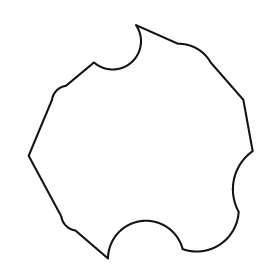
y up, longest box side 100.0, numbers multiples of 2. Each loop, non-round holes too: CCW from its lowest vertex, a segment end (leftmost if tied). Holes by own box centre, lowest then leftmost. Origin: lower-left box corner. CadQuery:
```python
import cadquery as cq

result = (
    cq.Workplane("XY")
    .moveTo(34.0, 0.0)
    .threePointArc((48.0, 16.0), (66.0, 4.0))
    .threePointArc((82.0, 6.0), (90.0, 20.0))
    .threePointArc((88.0, 34.0), (96.0, 46.0))
    .lineTo(92.0, 68.0)
    .lineTo(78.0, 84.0)
    .threePointArc((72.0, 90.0), (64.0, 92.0))
    .lineTo(46.0, 100.0)
    .threePointArc((44.0, 84.0), (28.0, 84.0))
    .lineTo(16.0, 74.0)
    .threePointArc((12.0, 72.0), (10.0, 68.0))
    .lineTo(0.0, 44.0)
    .lineTo(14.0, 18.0)
    .threePointArc((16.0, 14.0), (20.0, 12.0))
    .close()
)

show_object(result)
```